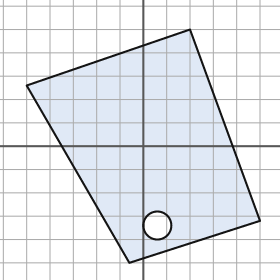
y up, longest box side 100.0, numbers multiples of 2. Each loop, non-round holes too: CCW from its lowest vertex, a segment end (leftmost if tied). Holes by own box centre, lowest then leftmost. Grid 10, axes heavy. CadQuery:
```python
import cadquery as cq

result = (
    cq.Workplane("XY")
    .moveTo(-6.0, -50.0)
    .lineTo(50.0, -32.0)
    .lineTo(20.0, 50.0)
    .lineTo(-50.0, 26.0)
    .close()
    .moveTo(6.0, -34.0)
    .circle(6.0)
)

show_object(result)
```